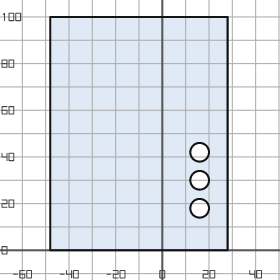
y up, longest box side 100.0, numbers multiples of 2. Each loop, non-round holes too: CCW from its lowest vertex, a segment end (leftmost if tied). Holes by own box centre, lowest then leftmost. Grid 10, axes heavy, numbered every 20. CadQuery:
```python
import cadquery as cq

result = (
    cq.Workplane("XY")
    .moveTo(-48.0, 0.0)
    .lineTo(28.0, 0.0)
    .lineTo(28.0, 100.0)
    .lineTo(-48.0, 100.0)
    .close()
    .moveTo(16.0, 18.0)
    .circle(4.0)
    .moveTo(16.0, 30.0)
    .circle(4.0)
    .moveTo(16.0, 42.0)
    .circle(4.0)
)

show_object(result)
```